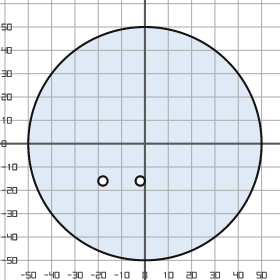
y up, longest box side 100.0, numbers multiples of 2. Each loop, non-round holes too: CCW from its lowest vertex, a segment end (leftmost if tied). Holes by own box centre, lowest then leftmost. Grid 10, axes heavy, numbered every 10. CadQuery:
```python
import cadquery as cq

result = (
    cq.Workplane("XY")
    .moveTo(0.0, 0.0)
    .circle(50.0)
    .moveTo(-18.0, -16.0)
    .circle(2.0)
    .moveTo(-2.0, -16.0)
    .circle(2.0)
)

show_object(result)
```